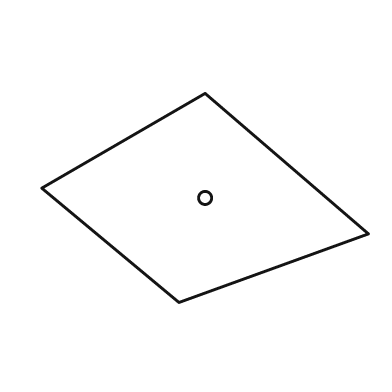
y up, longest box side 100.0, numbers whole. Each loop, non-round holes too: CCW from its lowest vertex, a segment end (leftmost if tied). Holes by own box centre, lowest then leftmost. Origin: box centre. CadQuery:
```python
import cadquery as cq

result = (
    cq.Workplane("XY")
    .moveTo(-8.0, -32.0)
    .lineTo(50.0, -11.0)
    .lineTo(0.0, 32.0)
    .lineTo(-50.0, 3.0)
    .close()
    .moveTo(0.0, 0.0)
    .circle(2.0)
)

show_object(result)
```